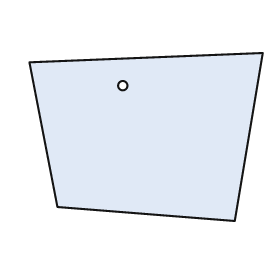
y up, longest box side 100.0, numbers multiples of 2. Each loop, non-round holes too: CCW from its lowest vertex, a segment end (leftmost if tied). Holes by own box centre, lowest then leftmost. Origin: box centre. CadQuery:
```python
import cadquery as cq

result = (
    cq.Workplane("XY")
    .moveTo(38.0, -36.0)
    .lineTo(50.0, 36.0)
    .lineTo(-50.0, 32.0)
    .lineTo(-38.0, -30.0)
    .close()
    .moveTo(-10.0, 22.0)
    .circle(2.0)
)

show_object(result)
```